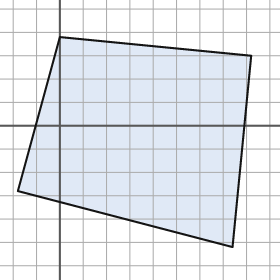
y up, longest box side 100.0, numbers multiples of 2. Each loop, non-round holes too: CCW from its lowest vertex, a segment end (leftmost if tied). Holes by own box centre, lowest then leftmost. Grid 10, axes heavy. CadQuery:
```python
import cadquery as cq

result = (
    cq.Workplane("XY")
    .moveTo(74.0, -52.0)
    .lineTo(82.0, 30.0)
    .lineTo(0.0, 38.0)
    .lineTo(-18.0, -28.0)
    .close()
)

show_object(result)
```